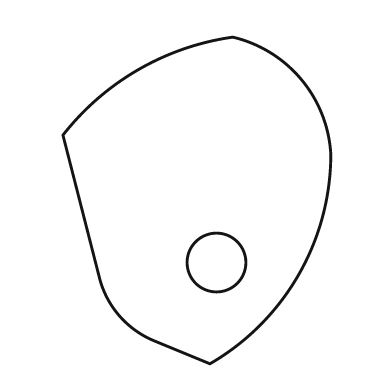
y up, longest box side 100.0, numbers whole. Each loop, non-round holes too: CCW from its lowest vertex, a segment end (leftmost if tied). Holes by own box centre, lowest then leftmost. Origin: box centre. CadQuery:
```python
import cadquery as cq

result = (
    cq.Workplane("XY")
    .moveTo(4.0, -50.0)
    .threePointArc((31.0, -23.0), (41.0, 14.0))
    .threePointArc((32.0, 37.0), (11.0, 50.0))
    .threePointArc((-18.0, 40.0), (-41.0, 20.0))
    .lineTo(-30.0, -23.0)
    .threePointArc((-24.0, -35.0), (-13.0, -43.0))
    .close()
    .moveTo(6.0, -19.0)
    .circle(9.0)
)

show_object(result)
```